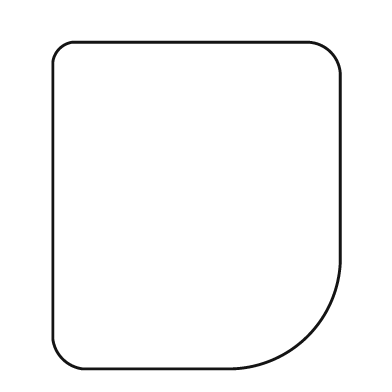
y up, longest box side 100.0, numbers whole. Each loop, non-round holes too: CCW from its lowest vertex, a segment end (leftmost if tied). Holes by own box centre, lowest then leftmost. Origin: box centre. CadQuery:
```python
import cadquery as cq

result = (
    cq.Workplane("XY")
    .moveTo(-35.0, -50.0)
    .lineTo(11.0, -50.0)
    .threePointArc((34.0, -40.0), (44.0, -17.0))
    .lineTo(44.0, 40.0)
    .threePointArc((41.0, 47.0), (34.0, 50.0))
    .lineTo(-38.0, 50.0)
    .threePointArc((-42.0, 48.0), (-44.0, 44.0))
    .lineTo(-44.0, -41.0)
    .threePointArc((-41.0, -47.0), (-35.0, -50.0))
    .close()
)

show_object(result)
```